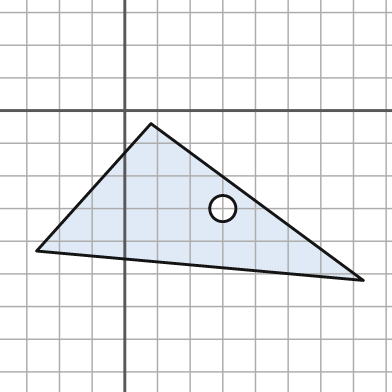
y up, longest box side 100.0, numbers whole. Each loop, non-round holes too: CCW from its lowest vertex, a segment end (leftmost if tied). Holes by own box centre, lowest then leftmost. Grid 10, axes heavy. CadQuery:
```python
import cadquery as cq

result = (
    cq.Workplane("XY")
    .moveTo(73.0, -52.0)
    .lineTo(8.0, -4.0)
    .lineTo(-27.0, -43.0)
    .close()
    .moveTo(30.0, -30.0)
    .circle(4.0)
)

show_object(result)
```